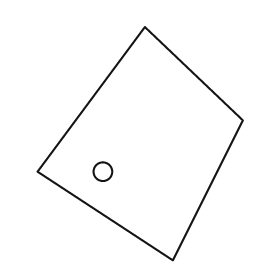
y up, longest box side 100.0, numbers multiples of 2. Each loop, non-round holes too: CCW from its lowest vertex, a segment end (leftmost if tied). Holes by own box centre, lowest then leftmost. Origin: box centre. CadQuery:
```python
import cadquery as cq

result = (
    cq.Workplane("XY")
    .moveTo(14.0, -50.0)
    .lineTo(44.0, 10.0)
    .lineTo(2.0, 50.0)
    .lineTo(-44.0, -12.0)
    .close()
    .moveTo(-16.0, -12.0)
    .circle(4.0)
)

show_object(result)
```